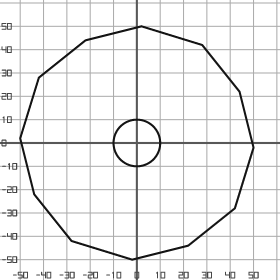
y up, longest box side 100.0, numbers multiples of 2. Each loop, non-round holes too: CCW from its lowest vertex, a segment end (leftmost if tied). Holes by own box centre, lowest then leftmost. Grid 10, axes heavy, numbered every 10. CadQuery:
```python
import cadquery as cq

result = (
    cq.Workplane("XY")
    .moveTo(-2.0, -50.0)
    .lineTo(22.0, -44.0)
    .lineTo(42.0, -28.0)
    .lineTo(50.0, -2.0)
    .lineTo(44.0, 22.0)
    .lineTo(28.0, 42.0)
    .lineTo(2.0, 50.0)
    .lineTo(-22.0, 44.0)
    .lineTo(-42.0, 28.0)
    .lineTo(-50.0, 2.0)
    .lineTo(-44.0, -22.0)
    .lineTo(-28.0, -42.0)
    .close()
    .moveTo(0.0, 0.0)
    .circle(10.0)
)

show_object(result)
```